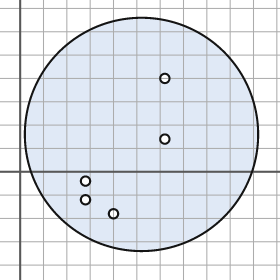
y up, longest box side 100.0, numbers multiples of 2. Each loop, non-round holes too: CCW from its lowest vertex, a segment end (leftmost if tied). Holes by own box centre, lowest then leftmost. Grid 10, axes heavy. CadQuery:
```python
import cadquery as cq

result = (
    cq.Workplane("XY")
    .moveTo(52.0, 16.0)
    .circle(50.0)
    .moveTo(40.0, -18.0)
    .circle(2.0)
    .moveTo(28.0, -12.0)
    .circle(2.0)
    .moveTo(28.0, -4.0)
    .circle(2.0)
    .moveTo(62.0, 14.0)
    .circle(2.0)
    .moveTo(62.0, 40.0)
    .circle(2.0)
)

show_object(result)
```